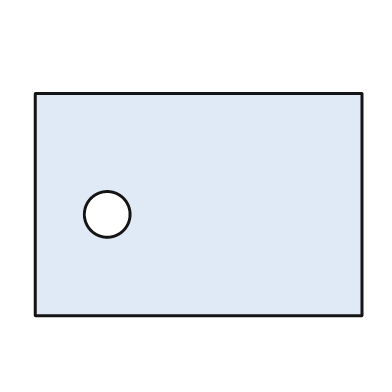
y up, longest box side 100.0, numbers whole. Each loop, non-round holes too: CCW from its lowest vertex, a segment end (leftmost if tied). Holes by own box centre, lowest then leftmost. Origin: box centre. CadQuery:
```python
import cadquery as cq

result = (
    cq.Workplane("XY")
    .moveTo(-50.0, -34.0)
    .lineTo(50.0, -34.0)
    .lineTo(50.0, 34.0)
    .lineTo(-50.0, 34.0)
    .close()
    .moveTo(-28.0, -3.0)
    .circle(7.0)
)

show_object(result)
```